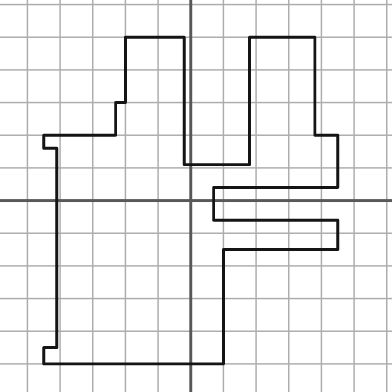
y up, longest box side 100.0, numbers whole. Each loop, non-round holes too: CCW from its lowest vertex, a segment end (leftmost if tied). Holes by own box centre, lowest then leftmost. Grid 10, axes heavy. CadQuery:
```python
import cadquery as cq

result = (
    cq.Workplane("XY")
    .moveTo(-45.0, -50.0)
    .lineTo(10.0, -50.0)
    .lineTo(10.0, -15.0)
    .lineTo(45.0, -15.0)
    .lineTo(45.0, -6.0)
    .lineTo(7.0, -6.0)
    .lineTo(7.0, 4.0)
    .lineTo(45.0, 4.0)
    .lineTo(45.0, 20.0)
    .lineTo(38.0, 20.0)
    .lineTo(38.0, 50.0)
    .lineTo(18.0, 50.0)
    .lineTo(18.0, 11.0)
    .lineTo(-2.0, 11.0)
    .lineTo(-2.0, 50.0)
    .lineTo(-20.0, 50.0)
    .lineTo(-20.0, 30.0)
    .lineTo(-23.0, 30.0)
    .lineTo(-23.0, 20.0)
    .lineTo(-45.0, 20.0)
    .lineTo(-45.0, 16.0)
    .lineTo(-41.0, 16.0)
    .lineTo(-41.0, -45.0)
    .lineTo(-45.0, -45.0)
    .close()
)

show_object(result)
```